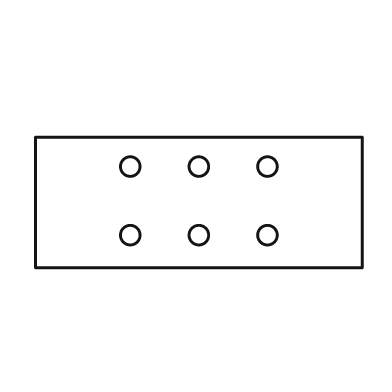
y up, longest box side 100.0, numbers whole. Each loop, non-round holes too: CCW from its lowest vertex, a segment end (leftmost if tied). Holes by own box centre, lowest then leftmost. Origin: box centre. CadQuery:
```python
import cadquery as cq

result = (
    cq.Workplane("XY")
    .moveTo(-50.0, -20.0)
    .lineTo(50.0, -20.0)
    .lineTo(50.0, 20.0)
    .lineTo(-50.0, 20.0)
    .close()
    .moveTo(-21.0, -10.0)
    .circle(3.0)
    .moveTo(0.0, -10.0)
    .circle(3.0)
    .moveTo(21.0, -10.0)
    .circle(3.0)
    .moveTo(-21.0, 11.0)
    .circle(3.0)
    .moveTo(0.0, 11.0)
    .circle(3.0)
    .moveTo(21.0, 11.0)
    .circle(3.0)
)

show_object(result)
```